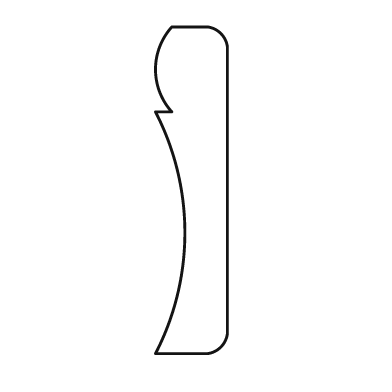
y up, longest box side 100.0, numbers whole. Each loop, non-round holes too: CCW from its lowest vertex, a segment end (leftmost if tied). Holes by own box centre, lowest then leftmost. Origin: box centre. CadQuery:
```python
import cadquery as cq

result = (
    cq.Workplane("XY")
    .moveTo(-11.0, -50.0)
    .lineTo(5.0, -50.0)
    .threePointArc((9.0, -48.0), (11.0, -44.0))
    .lineTo(11.0, 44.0)
    .threePointArc((9.0, 48.0), (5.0, 50.0))
    .lineTo(-6.0, 50.0)
    .threePointArc((-11.0, 37.0), (-6.0, 24.0))
    .lineTo(-11.0, 24.0)
    .threePointArc((-2.0, -13.0), (-11.0, -50.0))
    .close()
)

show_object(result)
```